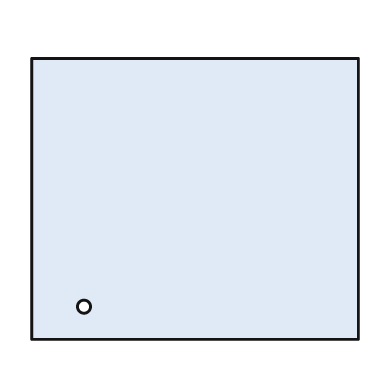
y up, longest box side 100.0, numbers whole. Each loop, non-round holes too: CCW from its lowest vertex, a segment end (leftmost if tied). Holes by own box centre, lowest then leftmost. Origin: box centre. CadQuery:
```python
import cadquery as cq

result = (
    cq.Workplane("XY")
    .moveTo(-50.0, -43.0)
    .lineTo(50.0, -43.0)
    .lineTo(50.0, 43.0)
    .lineTo(-50.0, 43.0)
    .close()
    .moveTo(-34.0, -33.0)
    .circle(2.0)
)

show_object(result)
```